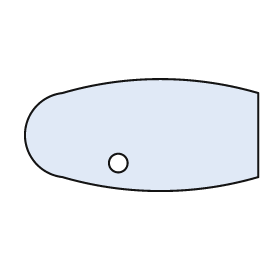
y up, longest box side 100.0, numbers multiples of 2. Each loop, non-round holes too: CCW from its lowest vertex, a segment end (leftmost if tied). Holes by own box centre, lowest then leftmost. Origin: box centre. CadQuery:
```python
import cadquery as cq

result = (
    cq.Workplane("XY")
    .moveTo(-34.0, -18.0)
    .threePointArc((8.0, -24.0), (50.0, -18.0))
    .lineTo(50.0, 18.0)
    .threePointArc((8.0, 24.0), (-34.0, 18.0))
    .threePointArc((-50.0, 0.0), (-34.0, -18.0))
    .close()
    .moveTo(-10.0, -12.0)
    .circle(4.0)
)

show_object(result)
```